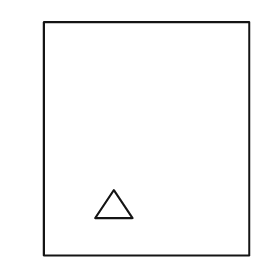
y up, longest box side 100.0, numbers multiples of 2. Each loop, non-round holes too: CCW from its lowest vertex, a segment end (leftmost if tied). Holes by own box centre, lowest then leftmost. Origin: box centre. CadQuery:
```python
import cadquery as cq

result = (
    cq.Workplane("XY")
    .moveTo(-44.0, -50.0)
    .lineTo(44.0, -50.0)
    .lineTo(44.0, 50.0)
    .lineTo(-44.0, 50.0)
    .close()
    .moveTo(-22.0, -34.0)
    .lineTo(-6.0, -34.0)
    .lineTo(-14.0, -22.0)
    .close()
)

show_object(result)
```